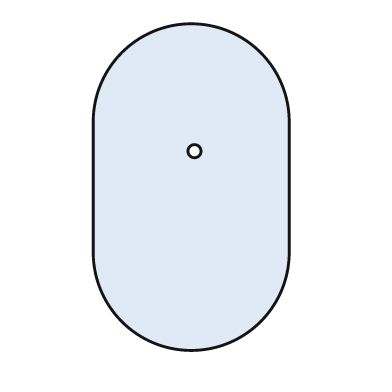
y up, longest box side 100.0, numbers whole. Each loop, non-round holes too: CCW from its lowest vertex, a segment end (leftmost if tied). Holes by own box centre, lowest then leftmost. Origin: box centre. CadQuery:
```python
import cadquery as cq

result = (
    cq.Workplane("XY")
    .moveTo(-30.0, -20.0)
    .threePointArc((0.0, -50.0), (30.0, -20.0))
    .lineTo(30.0, 20.0)
    .threePointArc((0.0, 50.0), (-30.0, 20.0))
    .close()
    .moveTo(1.0, 11.0)
    .circle(2.0)
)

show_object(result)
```